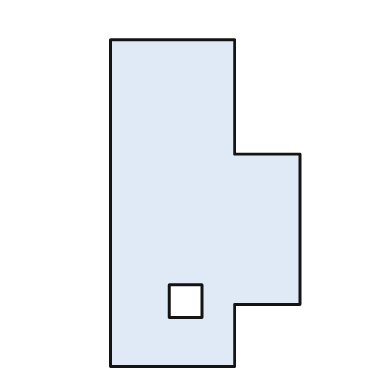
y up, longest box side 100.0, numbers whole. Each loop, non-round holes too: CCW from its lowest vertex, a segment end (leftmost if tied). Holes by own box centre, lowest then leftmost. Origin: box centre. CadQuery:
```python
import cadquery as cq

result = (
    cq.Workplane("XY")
    .moveTo(-29.0, -50.0)
    .lineTo(9.0, -50.0)
    .lineTo(9.0, -31.0)
    .lineTo(29.0, -31.0)
    .lineTo(29.0, 15.0)
    .lineTo(9.0, 15.0)
    .lineTo(9.0, 50.0)
    .lineTo(-29.0, 50.0)
    .close()
    .moveTo(-11.0, -35.0)
    .lineTo(-1.0, -35.0)
    .lineTo(-1.0, -25.0)
    .lineTo(-11.0, -25.0)
    .close()
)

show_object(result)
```